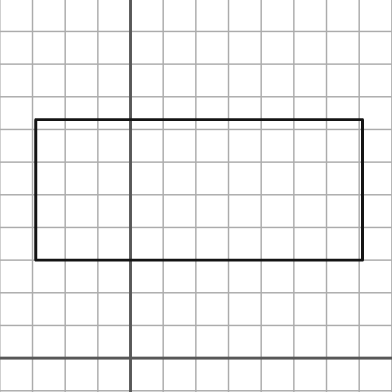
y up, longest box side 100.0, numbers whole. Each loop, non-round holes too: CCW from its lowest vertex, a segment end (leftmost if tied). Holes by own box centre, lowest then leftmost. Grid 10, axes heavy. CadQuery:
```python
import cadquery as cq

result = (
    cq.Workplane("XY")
    .moveTo(-29.0, 30.0)
    .lineTo(71.0, 30.0)
    .lineTo(71.0, 73.0)
    .lineTo(-29.0, 73.0)
    .close()
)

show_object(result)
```